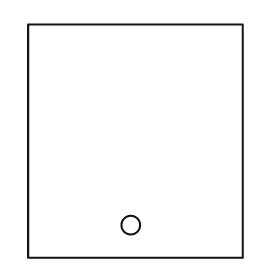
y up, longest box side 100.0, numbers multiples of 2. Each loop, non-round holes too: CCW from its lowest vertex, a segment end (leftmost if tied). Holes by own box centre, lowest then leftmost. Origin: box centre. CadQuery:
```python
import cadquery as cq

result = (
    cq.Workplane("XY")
    .moveTo(-46.0, -50.0)
    .lineTo(46.0, -50.0)
    .lineTo(46.0, 50.0)
    .lineTo(-46.0, 50.0)
    .close()
    .moveTo(-2.0, -36.0)
    .circle(4.0)
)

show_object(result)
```